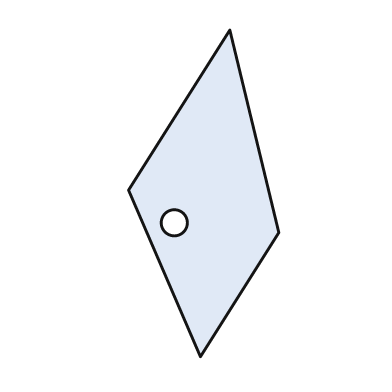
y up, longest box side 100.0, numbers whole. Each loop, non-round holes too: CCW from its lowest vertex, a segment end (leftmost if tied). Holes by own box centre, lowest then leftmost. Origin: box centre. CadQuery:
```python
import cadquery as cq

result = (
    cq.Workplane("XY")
    .moveTo(-1.0, -50.0)
    .lineTo(23.0, -12.0)
    .lineTo(8.0, 50.0)
    .lineTo(-23.0, 1.0)
    .close()
    .moveTo(-9.0, -9.0)
    .circle(4.0)
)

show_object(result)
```